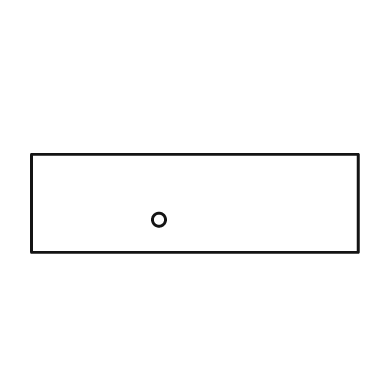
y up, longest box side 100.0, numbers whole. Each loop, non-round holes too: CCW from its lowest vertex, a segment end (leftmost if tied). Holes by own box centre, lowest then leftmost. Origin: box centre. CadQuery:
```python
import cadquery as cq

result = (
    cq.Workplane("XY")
    .moveTo(-50.0, -15.0)
    .lineTo(50.0, -15.0)
    .lineTo(50.0, 15.0)
    .lineTo(-50.0, 15.0)
    .close()
    .moveTo(-11.0, -5.0)
    .circle(2.0)
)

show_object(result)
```